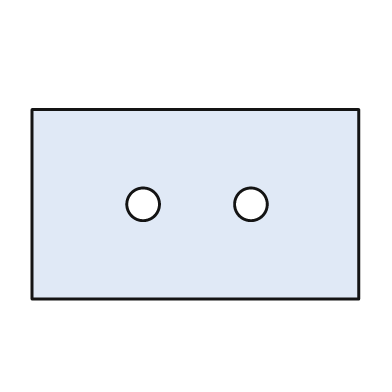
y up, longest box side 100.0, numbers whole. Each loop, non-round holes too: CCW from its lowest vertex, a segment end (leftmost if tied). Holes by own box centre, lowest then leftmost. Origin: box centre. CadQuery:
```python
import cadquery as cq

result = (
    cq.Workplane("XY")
    .moveTo(-50.0, -29.0)
    .lineTo(50.0, -29.0)
    .lineTo(50.0, 29.0)
    .lineTo(-50.0, 29.0)
    .close()
    .moveTo(-16.0, 0.0)
    .circle(5.0)
    .moveTo(17.0, 0.0)
    .circle(5.0)
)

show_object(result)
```